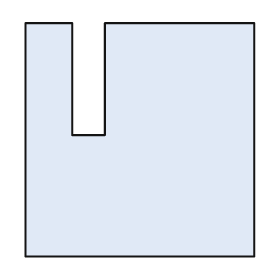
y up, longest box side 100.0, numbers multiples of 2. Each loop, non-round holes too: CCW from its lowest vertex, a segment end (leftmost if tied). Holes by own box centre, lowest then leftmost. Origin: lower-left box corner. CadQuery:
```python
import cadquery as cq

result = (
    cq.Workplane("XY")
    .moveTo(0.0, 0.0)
    .lineTo(98.0, 0.0)
    .lineTo(98.0, 100.0)
    .lineTo(34.0, 100.0)
    .lineTo(34.0, 52.0)
    .lineTo(20.0, 52.0)
    .lineTo(20.0, 100.0)
    .lineTo(0.0, 100.0)
    .close()
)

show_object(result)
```